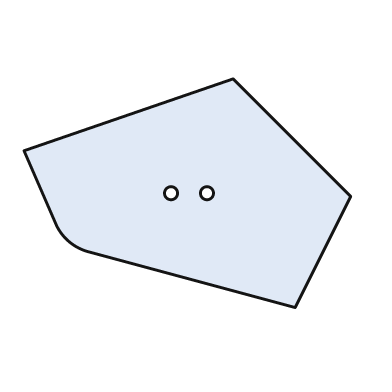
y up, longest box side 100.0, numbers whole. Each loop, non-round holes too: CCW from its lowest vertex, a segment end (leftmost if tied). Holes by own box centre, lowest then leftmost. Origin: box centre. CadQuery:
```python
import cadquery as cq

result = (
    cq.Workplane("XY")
    .moveTo(33.0, -35.0)
    .lineTo(50.0, -1.0)
    .lineTo(14.0, 35.0)
    .lineTo(-50.0, 13.0)
    .lineTo(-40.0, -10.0)
    .threePointArc((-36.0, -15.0), (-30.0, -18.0))
    .close()
    .moveTo(-5.0, 0.0)
    .circle(2.0)
    .moveTo(6.0, 0.0)
    .circle(2.0)
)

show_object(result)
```